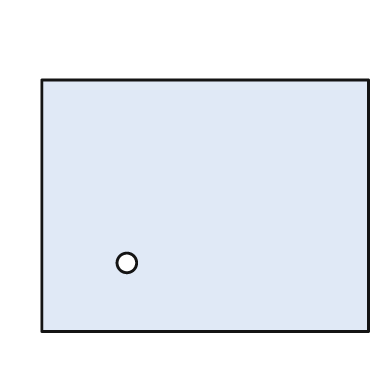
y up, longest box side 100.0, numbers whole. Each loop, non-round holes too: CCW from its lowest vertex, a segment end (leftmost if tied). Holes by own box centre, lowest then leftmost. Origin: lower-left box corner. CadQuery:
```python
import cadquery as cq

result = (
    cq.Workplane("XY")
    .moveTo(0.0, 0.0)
    .lineTo(100.0, 0.0)
    .lineTo(100.0, 77.0)
    .lineTo(0.0, 77.0)
    .close()
    .moveTo(26.0, 21.0)
    .circle(3.0)
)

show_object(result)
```